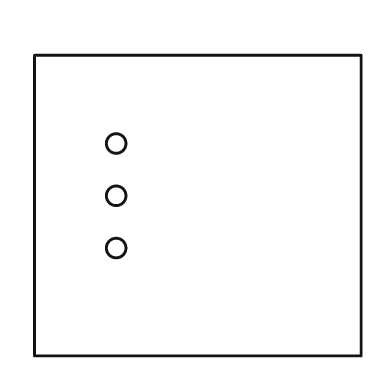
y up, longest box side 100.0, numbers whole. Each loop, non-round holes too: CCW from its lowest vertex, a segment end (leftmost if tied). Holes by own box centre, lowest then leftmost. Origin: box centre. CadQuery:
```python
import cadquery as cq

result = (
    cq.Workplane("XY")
    .moveTo(-50.0, -46.0)
    .lineTo(50.0, -46.0)
    .lineTo(50.0, 46.0)
    .lineTo(-50.0, 46.0)
    .close()
    .moveTo(-25.0, -13.0)
    .circle(3.0)
    .moveTo(-25.0, 3.0)
    .circle(3.0)
    .moveTo(-25.0, 19.0)
    .circle(3.0)
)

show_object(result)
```